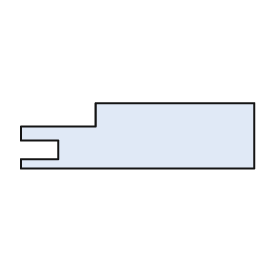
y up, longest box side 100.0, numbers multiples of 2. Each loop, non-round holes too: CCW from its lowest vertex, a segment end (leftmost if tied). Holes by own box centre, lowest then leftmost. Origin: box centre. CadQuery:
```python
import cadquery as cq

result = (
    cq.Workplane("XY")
    .moveTo(-50.0, -14.0)
    .lineTo(50.0, -14.0)
    .lineTo(50.0, 14.0)
    .lineTo(-18.0, 14.0)
    .lineTo(-18.0, 4.0)
    .lineTo(-50.0, 4.0)
    .lineTo(-50.0, -2.0)
    .lineTo(-34.0, -2.0)
    .lineTo(-34.0, -10.0)
    .lineTo(-50.0, -10.0)
    .close()
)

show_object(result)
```